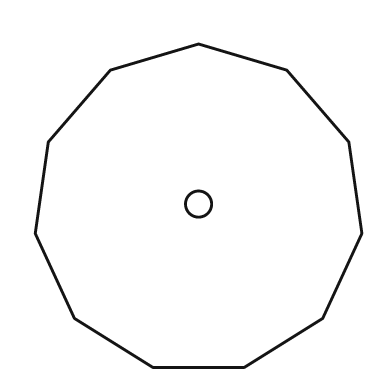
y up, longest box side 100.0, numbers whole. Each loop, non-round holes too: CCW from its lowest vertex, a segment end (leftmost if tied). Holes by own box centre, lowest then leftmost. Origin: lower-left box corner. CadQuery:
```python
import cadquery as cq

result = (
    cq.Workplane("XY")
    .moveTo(36.0, 0.0)
    .lineTo(64.0, 0.0)
    .lineTo(88.0, 15.0)
    .lineTo(100.0, 41.0)
    .lineTo(96.0, 69.0)
    .lineTo(77.0, 91.0)
    .lineTo(50.0, 99.0)
    .lineTo(23.0, 91.0)
    .lineTo(4.0, 69.0)
    .lineTo(0.0, 41.0)
    .lineTo(12.0, 15.0)
    .close()
    .moveTo(50.0, 50.0)
    .circle(4.0)
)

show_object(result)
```